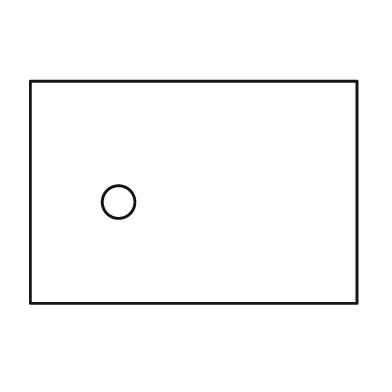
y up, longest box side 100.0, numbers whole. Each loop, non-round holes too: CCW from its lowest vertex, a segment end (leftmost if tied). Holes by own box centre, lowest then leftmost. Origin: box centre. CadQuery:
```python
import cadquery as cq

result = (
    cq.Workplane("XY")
    .moveTo(-50.0, -34.0)
    .lineTo(50.0, -34.0)
    .lineTo(50.0, 34.0)
    .lineTo(-50.0, 34.0)
    .close()
    .moveTo(-23.0, -3.0)
    .circle(5.0)
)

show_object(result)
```